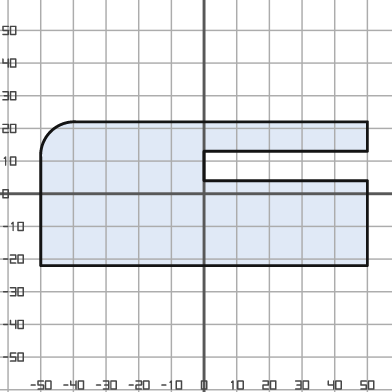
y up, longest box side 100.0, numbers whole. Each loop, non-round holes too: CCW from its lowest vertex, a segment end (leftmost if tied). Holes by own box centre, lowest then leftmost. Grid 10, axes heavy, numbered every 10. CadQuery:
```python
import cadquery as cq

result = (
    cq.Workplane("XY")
    .moveTo(-50.0, -22.0)
    .lineTo(50.0, -22.0)
    .lineTo(50.0, 4.0)
    .lineTo(0.0, 4.0)
    .lineTo(0.0, 13.0)
    .lineTo(50.0, 13.0)
    .lineTo(50.0, 22.0)
    .lineTo(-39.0, 22.0)
    .threePointArc((-47.0, 19.0), (-50.0, 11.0))
    .close()
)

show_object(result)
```